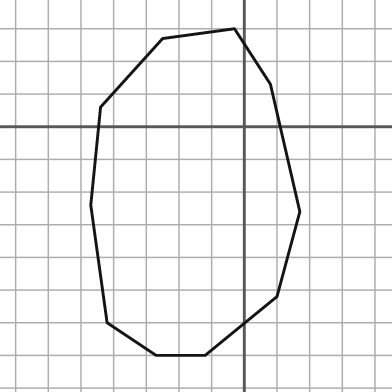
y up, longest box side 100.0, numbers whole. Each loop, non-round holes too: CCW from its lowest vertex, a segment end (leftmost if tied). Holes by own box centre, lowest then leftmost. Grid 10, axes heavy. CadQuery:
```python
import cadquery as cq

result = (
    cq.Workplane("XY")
    .moveTo(-27.0, -70.0)
    .lineTo(-12.0, -70.0)
    .lineTo(10.0, -52.0)
    .lineTo(17.0, -26.0)
    .lineTo(8.0, 13.0)
    .lineTo(-3.0, 30.0)
    .lineTo(-25.0, 27.0)
    .lineTo(-44.0, 6.0)
    .lineTo(-47.0, -24.0)
    .lineTo(-42.0, -60.0)
    .close()
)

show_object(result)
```